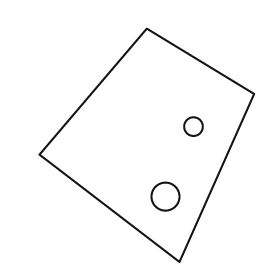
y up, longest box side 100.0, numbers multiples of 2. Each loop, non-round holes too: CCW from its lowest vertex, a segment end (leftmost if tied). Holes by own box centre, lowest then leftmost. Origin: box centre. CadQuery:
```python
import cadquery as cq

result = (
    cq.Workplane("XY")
    .moveTo(14.0, -50.0)
    .lineTo(46.0, 22.0)
    .lineTo(0.0, 50.0)
    .lineTo(-46.0, -4.0)
    .close()
    .moveTo(8.0, -22.0)
    .circle(6.0)
    .moveTo(20.0, 8.0)
    .circle(4.0)
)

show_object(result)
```